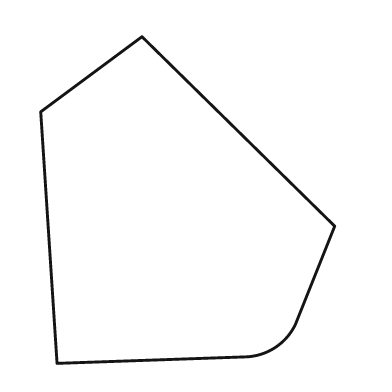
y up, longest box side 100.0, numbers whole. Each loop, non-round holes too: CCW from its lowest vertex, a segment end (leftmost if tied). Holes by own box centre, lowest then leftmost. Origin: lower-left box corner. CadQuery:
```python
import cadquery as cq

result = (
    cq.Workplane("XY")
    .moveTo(5.0, 0.0)
    .lineTo(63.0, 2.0)
    .threePointArc((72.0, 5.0), (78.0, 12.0))
    .lineTo(90.0, 42.0)
    .lineTo(31.0, 100.0)
    .lineTo(0.0, 77.0)
    .close()
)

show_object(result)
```